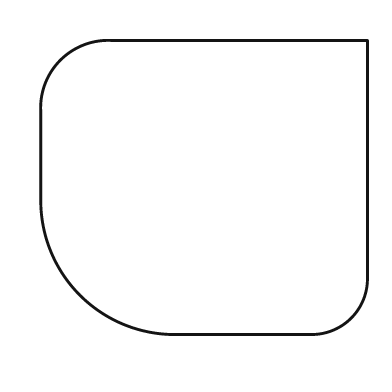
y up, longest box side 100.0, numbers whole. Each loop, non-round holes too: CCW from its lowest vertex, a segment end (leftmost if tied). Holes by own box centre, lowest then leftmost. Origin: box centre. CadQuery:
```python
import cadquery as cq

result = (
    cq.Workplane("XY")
    .moveTo(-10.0, -45.0)
    .lineTo(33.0, -45.0)
    .threePointArc((45.0, -40.0), (50.0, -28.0))
    .lineTo(50.0, 45.0)
    .lineTo(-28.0, 45.0)
    .threePointArc((-44.0, 39.0), (-50.0, 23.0))
    .lineTo(-50.0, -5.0)
    .threePointArc((-38.0, -33.0), (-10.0, -45.0))
    .close()
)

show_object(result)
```